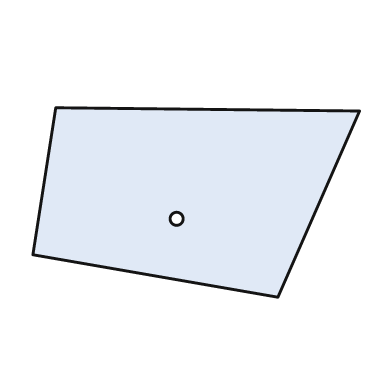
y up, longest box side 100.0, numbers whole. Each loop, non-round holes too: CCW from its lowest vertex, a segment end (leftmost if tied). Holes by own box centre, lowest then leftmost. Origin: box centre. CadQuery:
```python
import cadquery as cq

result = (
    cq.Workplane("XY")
    .moveTo(25.0, -29.0)
    .lineTo(50.0, 28.0)
    .lineTo(-43.0, 29.0)
    .lineTo(-50.0, -16.0)
    .close()
    .moveTo(-6.0, -5.0)
    .circle(2.0)
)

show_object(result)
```